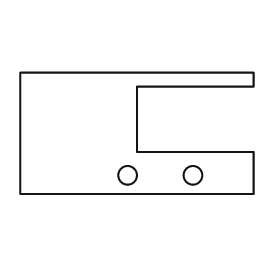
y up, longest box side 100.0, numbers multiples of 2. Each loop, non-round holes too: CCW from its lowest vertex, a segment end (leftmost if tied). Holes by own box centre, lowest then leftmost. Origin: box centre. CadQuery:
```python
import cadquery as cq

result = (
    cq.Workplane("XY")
    .moveTo(-50.0, -26.0)
    .lineTo(50.0, -26.0)
    .lineTo(50.0, -8.0)
    .lineTo(0.0, -8.0)
    .lineTo(0.0, 20.0)
    .lineTo(50.0, 20.0)
    .lineTo(50.0, 26.0)
    .lineTo(-50.0, 26.0)
    .close()
    .moveTo(-4.0, -18.0)
    .circle(4.0)
    .moveTo(24.0, -18.0)
    .circle(4.0)
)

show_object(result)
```